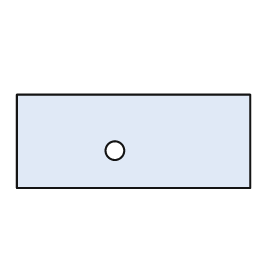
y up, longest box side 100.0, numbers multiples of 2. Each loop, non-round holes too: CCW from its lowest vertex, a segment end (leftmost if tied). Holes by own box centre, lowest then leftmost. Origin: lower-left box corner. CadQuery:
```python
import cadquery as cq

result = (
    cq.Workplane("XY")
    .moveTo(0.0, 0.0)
    .lineTo(100.0, 0.0)
    .lineTo(100.0, 40.0)
    .lineTo(0.0, 40.0)
    .close()
    .moveTo(42.0, 16.0)
    .circle(4.0)
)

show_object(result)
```